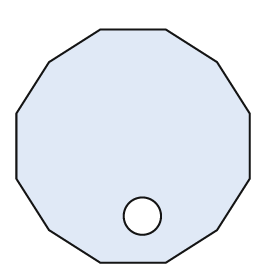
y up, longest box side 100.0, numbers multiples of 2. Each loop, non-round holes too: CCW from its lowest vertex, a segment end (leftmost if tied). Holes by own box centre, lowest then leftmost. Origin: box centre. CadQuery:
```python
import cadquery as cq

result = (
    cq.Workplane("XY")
    .moveTo(-14.0, -50.0)
    .lineTo(14.0, -50.0)
    .lineTo(36.0, -36.0)
    .lineTo(50.0, -14.0)
    .lineTo(50.0, 14.0)
    .lineTo(36.0, 36.0)
    .lineTo(14.0, 50.0)
    .lineTo(-14.0, 50.0)
    .lineTo(-36.0, 36.0)
    .lineTo(-50.0, 14.0)
    .lineTo(-50.0, -14.0)
    .lineTo(-36.0, -36.0)
    .close()
    .moveTo(4.0, -30.0)
    .circle(8.0)
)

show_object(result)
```